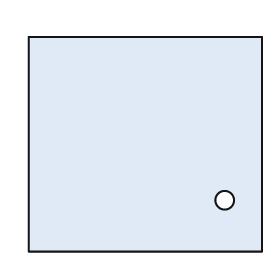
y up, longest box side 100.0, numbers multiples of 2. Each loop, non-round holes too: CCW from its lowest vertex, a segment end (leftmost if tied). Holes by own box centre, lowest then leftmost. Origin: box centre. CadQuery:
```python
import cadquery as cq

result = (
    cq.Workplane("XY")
    .moveTo(-50.0, -46.0)
    .lineTo(50.0, -46.0)
    .lineTo(50.0, 46.0)
    .lineTo(-50.0, 46.0)
    .close()
    .moveTo(34.0, -24.0)
    .circle(4.0)
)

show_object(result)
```